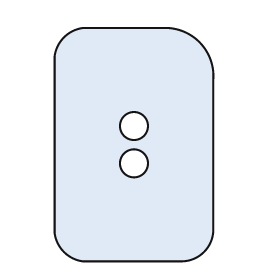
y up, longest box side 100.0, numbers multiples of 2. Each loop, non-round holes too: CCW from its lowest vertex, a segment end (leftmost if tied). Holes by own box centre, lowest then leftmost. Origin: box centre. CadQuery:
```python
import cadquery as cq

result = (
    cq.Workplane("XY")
    .moveTo(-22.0, -50.0)
    .lineTo(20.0, -50.0)
    .threePointArc((30.0, -46.0), (34.0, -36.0))
    .lineTo(34.0, 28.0)
    .threePointArc((28.0, 44.0), (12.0, 50.0))
    .lineTo(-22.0, 50.0)
    .threePointArc((-30.0, 46.0), (-34.0, 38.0))
    .lineTo(-34.0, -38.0)
    .threePointArc((-30.0, -46.0), (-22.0, -50.0))
    .close()
    .moveTo(0.0, -8.0)
    .circle(6.0)
    .moveTo(0.0, 8.0)
    .circle(6.0)
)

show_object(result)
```